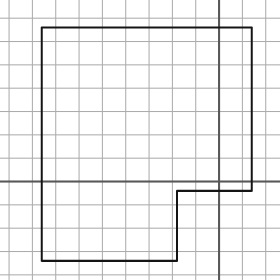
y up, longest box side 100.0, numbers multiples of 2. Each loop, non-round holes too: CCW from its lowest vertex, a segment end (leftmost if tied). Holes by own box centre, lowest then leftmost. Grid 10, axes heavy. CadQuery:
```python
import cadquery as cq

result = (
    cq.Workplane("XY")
    .moveTo(-76.0, -34.0)
    .lineTo(-18.0, -34.0)
    .lineTo(-18.0, -4.0)
    .lineTo(14.0, -4.0)
    .lineTo(14.0, 66.0)
    .lineTo(-76.0, 66.0)
    .close()
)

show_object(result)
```